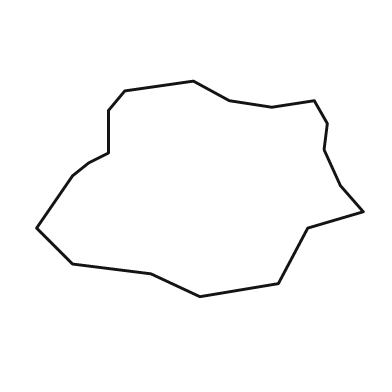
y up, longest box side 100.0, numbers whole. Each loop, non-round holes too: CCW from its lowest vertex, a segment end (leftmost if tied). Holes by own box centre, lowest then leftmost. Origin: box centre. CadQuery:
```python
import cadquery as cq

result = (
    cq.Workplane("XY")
    .moveTo(0.0, -33.0)
    .lineTo(24.0, -29.0)
    .lineTo(33.0, -12.0)
    .lineTo(50.0, -7.0)
    .lineTo(43.0, 1.0)
    .lineTo(38.0, 12.0)
    .lineTo(39.0, 20.0)
    .lineTo(35.0, 27.0)
    .lineTo(22.0, 25.0)
    .lineTo(9.0, 27.0)
    .lineTo(-2.0, 33.0)
    .lineTo(-23.0, 30.0)
    .lineTo(-28.0, 24.0)
    .lineTo(-28.0, 11.0)
    .lineTo(-34.0, 8.0)
    .lineTo(-39.0, 4.0)
    .lineTo(-50.0, -12.0)
    .lineTo(-39.0, -23.0)
    .lineTo(-15.0, -26.0)
    .close()
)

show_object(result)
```